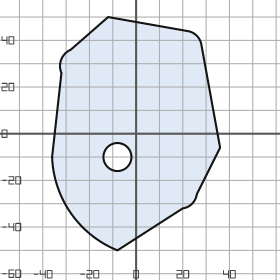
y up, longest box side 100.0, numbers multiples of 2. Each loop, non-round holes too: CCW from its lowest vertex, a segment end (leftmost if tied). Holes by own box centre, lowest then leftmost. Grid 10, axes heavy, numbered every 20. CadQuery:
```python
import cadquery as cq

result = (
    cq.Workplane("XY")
    .moveTo(-8.0, -50.0)
    .lineTo(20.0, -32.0)
    .threePointArc((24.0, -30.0), (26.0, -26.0))
    .lineTo(36.0, -6.0)
    .lineTo(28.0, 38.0)
    .threePointArc((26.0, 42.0), (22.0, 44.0))
    .lineTo(-12.0, 50.0)
    .lineTo(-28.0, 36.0)
    .threePointArc((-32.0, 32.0), (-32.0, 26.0))
    .lineTo(-36.0, -10.0)
    .threePointArc((-28.0, -34.0), (-8.0, -50.0))
    .close()
    .moveTo(-8.0, -10.0)
    .circle(6.0)
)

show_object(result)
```